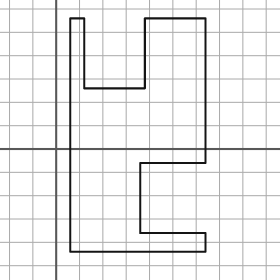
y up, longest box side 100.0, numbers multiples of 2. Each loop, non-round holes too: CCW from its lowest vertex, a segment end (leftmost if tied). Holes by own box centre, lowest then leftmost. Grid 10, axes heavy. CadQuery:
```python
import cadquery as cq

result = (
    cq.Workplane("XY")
    .moveTo(6.0, -44.0)
    .lineTo(64.0, -44.0)
    .lineTo(64.0, -36.0)
    .lineTo(36.0, -36.0)
    .lineTo(36.0, -6.0)
    .lineTo(64.0, -6.0)
    .lineTo(64.0, 56.0)
    .lineTo(38.0, 56.0)
    .lineTo(38.0, 26.0)
    .lineTo(12.0, 26.0)
    .lineTo(12.0, 56.0)
    .lineTo(6.0, 56.0)
    .close()
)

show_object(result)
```